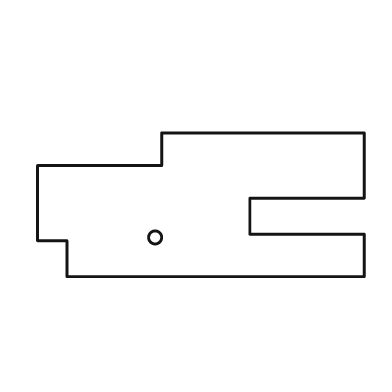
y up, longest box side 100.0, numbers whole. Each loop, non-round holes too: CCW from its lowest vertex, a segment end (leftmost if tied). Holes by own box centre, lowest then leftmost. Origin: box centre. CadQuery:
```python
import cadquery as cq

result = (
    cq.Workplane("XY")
    .moveTo(-41.0, -22.0)
    .lineTo(50.0, -22.0)
    .lineTo(50.0, -9.0)
    .lineTo(15.0, -9.0)
    .lineTo(15.0, 2.0)
    .lineTo(50.0, 2.0)
    .lineTo(50.0, 22.0)
    .lineTo(-12.0, 22.0)
    .lineTo(-12.0, 12.0)
    .lineTo(-50.0, 12.0)
    .lineTo(-50.0, -11.0)
    .lineTo(-41.0, -11.0)
    .close()
    .moveTo(-14.0, -10.0)
    .circle(2.0)
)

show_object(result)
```